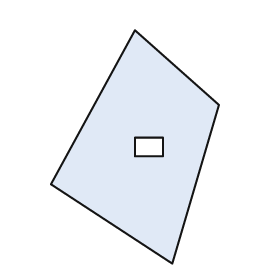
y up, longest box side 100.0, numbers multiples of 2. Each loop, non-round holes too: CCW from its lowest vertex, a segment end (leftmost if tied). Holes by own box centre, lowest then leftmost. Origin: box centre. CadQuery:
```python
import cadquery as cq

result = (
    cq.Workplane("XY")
    .moveTo(16.0, -50.0)
    .lineTo(36.0, 18.0)
    .lineTo(0.0, 50.0)
    .lineTo(-36.0, -16.0)
    .close()
    .moveTo(0.0, -4.0)
    .lineTo(12.0, -4.0)
    .lineTo(12.0, 4.0)
    .lineTo(0.0, 4.0)
    .close()
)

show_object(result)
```